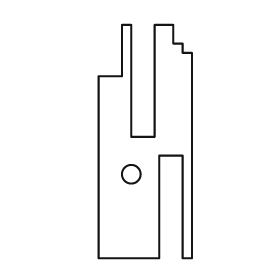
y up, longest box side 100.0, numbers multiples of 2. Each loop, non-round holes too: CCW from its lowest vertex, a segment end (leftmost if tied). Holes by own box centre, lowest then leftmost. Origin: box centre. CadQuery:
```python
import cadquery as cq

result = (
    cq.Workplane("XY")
    .moveTo(-20.0, -50.0)
    .lineTo(6.0, -50.0)
    .lineTo(6.0, -6.0)
    .lineTo(16.0, -6.0)
    .lineTo(16.0, -50.0)
    .lineTo(20.0, -50.0)
    .lineTo(20.0, 38.0)
    .lineTo(16.0, 38.0)
    .lineTo(16.0, 42.0)
    .lineTo(12.0, 42.0)
    .lineTo(12.0, 50.0)
    .lineTo(4.0, 50.0)
    .lineTo(4.0, 2.0)
    .lineTo(-6.0, 2.0)
    .lineTo(-6.0, 50.0)
    .lineTo(-10.0, 50.0)
    .lineTo(-10.0, 28.0)
    .lineTo(-20.0, 28.0)
    .close()
    .moveTo(-6.0, -14.0)
    .circle(4.0)
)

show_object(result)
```